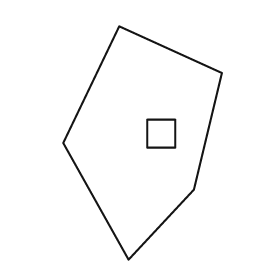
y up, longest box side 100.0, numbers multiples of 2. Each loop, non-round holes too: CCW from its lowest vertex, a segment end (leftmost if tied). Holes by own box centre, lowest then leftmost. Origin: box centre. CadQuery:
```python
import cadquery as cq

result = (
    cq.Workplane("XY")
    .moveTo(-6.0, -50.0)
    .lineTo(22.0, -20.0)
    .lineTo(34.0, 30.0)
    .lineTo(-10.0, 50.0)
    .lineTo(-34.0, 0.0)
    .close()
    .moveTo(2.0, -2.0)
    .lineTo(14.0, -2.0)
    .lineTo(14.0, 10.0)
    .lineTo(2.0, 10.0)
    .close()
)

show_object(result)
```